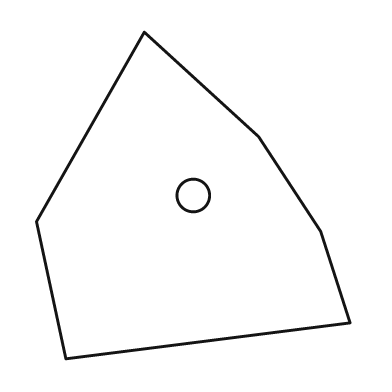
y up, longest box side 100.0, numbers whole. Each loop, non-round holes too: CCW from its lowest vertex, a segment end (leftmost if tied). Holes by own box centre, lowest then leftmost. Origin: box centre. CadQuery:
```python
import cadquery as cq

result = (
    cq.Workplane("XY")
    .moveTo(-39.0, -50.0)
    .lineTo(48.0, -39.0)
    .lineTo(39.0, -11.0)
    .lineTo(20.0, 18.0)
    .lineTo(-15.0, 50.0)
    .lineTo(-48.0, -8.0)
    .close()
    .moveTo(0.0, 0.0)
    .circle(5.0)
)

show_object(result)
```